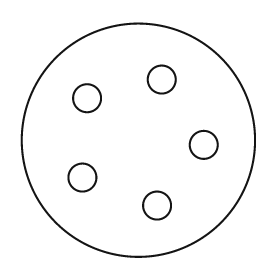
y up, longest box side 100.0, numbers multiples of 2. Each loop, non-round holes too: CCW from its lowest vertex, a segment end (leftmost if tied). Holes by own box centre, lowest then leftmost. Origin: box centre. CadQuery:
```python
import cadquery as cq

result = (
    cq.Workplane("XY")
    .moveTo(0.0, 0.0)
    .circle(50.0)
    .moveTo(8.0, -28.0)
    .circle(6.0)
    .moveTo(-24.0, -16.0)
    .circle(6.0)
    .moveTo(28.0, -2.0)
    .circle(6.0)
    .moveTo(-22.0, 18.0)
    .circle(6.0)
    .moveTo(10.0, 26.0)
    .circle(6.0)
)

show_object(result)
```